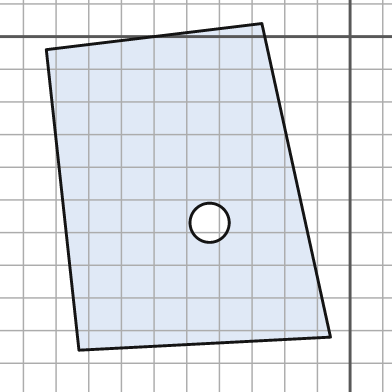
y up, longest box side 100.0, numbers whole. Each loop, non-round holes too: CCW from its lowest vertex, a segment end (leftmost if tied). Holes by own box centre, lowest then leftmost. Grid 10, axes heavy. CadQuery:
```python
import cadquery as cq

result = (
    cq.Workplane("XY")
    .moveTo(-83.0, -96.0)
    .lineTo(-6.0, -92.0)
    .lineTo(-27.0, 4.0)
    .lineTo(-93.0, -4.0)
    .close()
    .moveTo(-43.0, -57.0)
    .circle(6.0)
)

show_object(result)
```